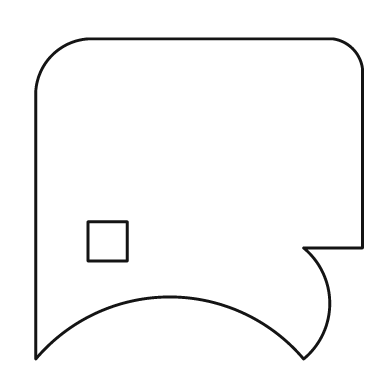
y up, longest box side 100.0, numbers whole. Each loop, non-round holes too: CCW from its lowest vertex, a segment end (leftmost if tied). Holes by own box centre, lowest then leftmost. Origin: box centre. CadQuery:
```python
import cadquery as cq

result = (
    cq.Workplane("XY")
    .moveTo(-50.0, -49.0)
    .threePointArc((-9.0, -30.0), (32.0, -49.0))
    .threePointArc((40.0, -32.0), (32.0, -15.0))
    .lineTo(50.0, -15.0)
    .lineTo(50.0, 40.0)
    .threePointArc((47.0, 46.0), (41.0, 49.0))
    .lineTo(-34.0, 49.0)
    .threePointArc((-45.0, 44.0), (-50.0, 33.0))
    .close()
    .moveTo(-34.0, -19.0)
    .lineTo(-22.0, -19.0)
    .lineTo(-22.0, -7.0)
    .lineTo(-34.0, -7.0)
    .close()
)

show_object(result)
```